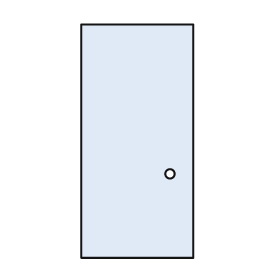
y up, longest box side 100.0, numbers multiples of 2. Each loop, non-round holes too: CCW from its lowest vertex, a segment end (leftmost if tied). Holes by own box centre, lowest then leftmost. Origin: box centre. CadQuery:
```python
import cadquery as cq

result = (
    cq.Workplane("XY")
    .moveTo(-24.0, -50.0)
    .lineTo(24.0, -50.0)
    .lineTo(24.0, 50.0)
    .lineTo(-24.0, 50.0)
    .close()
    .moveTo(14.0, -14.0)
    .circle(2.0)
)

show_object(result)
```